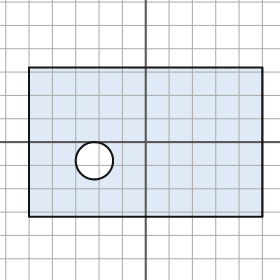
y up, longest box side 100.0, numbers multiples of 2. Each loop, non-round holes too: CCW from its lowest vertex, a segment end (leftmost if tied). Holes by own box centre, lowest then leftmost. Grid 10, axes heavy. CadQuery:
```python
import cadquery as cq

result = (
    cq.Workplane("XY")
    .moveTo(-50.0, -32.0)
    .lineTo(50.0, -32.0)
    .lineTo(50.0, 32.0)
    .lineTo(-50.0, 32.0)
    .close()
    .moveTo(-22.0, -8.0)
    .circle(8.0)
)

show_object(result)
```